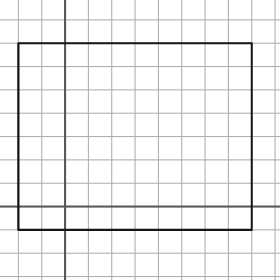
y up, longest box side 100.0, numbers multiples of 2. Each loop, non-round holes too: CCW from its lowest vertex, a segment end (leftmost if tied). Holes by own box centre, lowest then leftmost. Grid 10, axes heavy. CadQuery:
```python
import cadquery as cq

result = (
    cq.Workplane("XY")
    .moveTo(-20.0, -10.0)
    .lineTo(80.0, -10.0)
    .lineTo(80.0, 70.0)
    .lineTo(-20.0, 70.0)
    .close()
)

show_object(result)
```